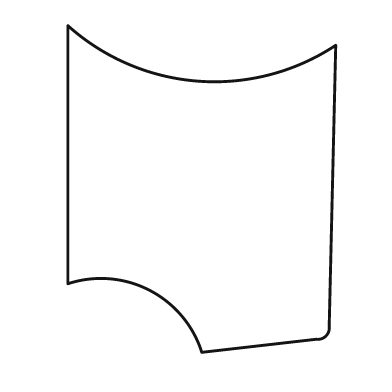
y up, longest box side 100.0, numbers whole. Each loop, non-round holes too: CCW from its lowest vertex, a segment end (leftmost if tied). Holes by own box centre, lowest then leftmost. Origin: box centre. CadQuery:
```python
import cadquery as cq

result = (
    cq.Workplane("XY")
    .moveTo(0.0, -50.0)
    .lineTo(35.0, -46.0)
    .threePointArc((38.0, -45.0), (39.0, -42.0))
    .lineTo(41.0, 44.0)
    .threePointArc((-1.0, 33.0), (-41.0, 50.0))
    .lineTo(-41.0, -29.0)
    .threePointArc((-16.0, -31.0), (0.0, -50.0))
    .close()
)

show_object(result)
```